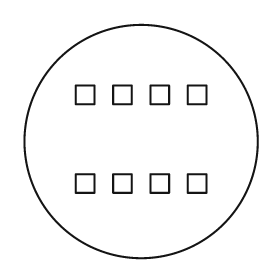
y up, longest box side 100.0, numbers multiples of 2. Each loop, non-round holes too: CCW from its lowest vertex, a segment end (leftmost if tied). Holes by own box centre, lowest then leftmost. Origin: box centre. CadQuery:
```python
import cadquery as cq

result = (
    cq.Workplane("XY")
    .moveTo(0.0, 0.0)
    .circle(50.0)
    .moveTo(-28.0, -22.0)
    .lineTo(-20.0, -22.0)
    .lineTo(-20.0, -14.0)
    .lineTo(-28.0, -14.0)
    .close()
    .moveTo(-12.0, -22.0)
    .lineTo(-4.0, -22.0)
    .lineTo(-4.0, -14.0)
    .lineTo(-12.0, -14.0)
    .close()
    .moveTo(4.0, -22.0)
    .lineTo(12.0, -22.0)
    .lineTo(12.0, -14.0)
    .lineTo(4.0, -14.0)
    .close()
    .moveTo(20.0, -22.0)
    .lineTo(28.0, -22.0)
    .lineTo(28.0, -14.0)
    .lineTo(20.0, -14.0)
    .close()
    .moveTo(-28.0, 16.0)
    .lineTo(-20.0, 16.0)
    .lineTo(-20.0, 24.0)
    .lineTo(-28.0, 24.0)
    .close()
    .moveTo(-12.0, 16.0)
    .lineTo(-4.0, 16.0)
    .lineTo(-4.0, 24.0)
    .lineTo(-12.0, 24.0)
    .close()
    .moveTo(4.0, 16.0)
    .lineTo(12.0, 16.0)
    .lineTo(12.0, 24.0)
    .lineTo(4.0, 24.0)
    .close()
    .moveTo(20.0, 16.0)
    .lineTo(28.0, 16.0)
    .lineTo(28.0, 24.0)
    .lineTo(20.0, 24.0)
    .close()
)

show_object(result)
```